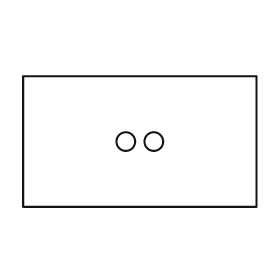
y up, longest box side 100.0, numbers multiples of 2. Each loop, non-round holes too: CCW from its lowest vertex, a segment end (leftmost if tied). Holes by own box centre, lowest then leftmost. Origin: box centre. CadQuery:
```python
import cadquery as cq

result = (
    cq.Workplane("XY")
    .moveTo(-50.0, -28.0)
    .lineTo(50.0, -28.0)
    .lineTo(50.0, 28.0)
    .lineTo(-50.0, 28.0)
    .close()
    .moveTo(-6.0, 0.0)
    .circle(4.0)
    .moveTo(6.0, 0.0)
    .circle(4.0)
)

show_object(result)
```